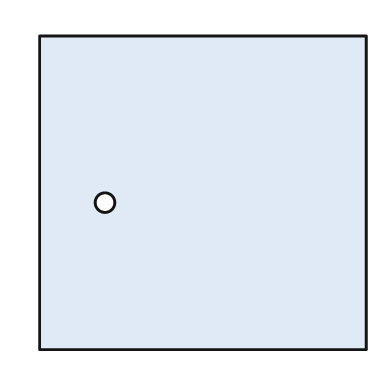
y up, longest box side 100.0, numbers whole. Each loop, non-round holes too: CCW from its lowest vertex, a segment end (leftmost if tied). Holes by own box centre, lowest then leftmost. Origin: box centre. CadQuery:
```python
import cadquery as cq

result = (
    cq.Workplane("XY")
    .moveTo(-50.0, -48.0)
    .lineTo(50.0, -48.0)
    .lineTo(50.0, 48.0)
    .lineTo(-50.0, 48.0)
    .close()
    .moveTo(-30.0, -3.0)
    .circle(3.0)
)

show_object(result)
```